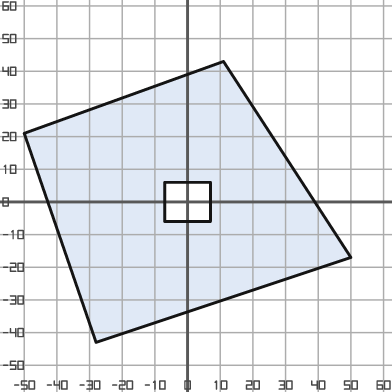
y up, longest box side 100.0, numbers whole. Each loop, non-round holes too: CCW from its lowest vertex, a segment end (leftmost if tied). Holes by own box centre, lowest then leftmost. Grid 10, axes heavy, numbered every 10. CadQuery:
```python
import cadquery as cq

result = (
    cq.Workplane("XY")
    .moveTo(-28.0, -43.0)
    .lineTo(50.0, -17.0)
    .lineTo(11.0, 43.0)
    .lineTo(-50.0, 21.0)
    .close()
    .moveTo(-7.0, -6.0)
    .lineTo(7.0, -6.0)
    .lineTo(7.0, 6.0)
    .lineTo(-7.0, 6.0)
    .close()
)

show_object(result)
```